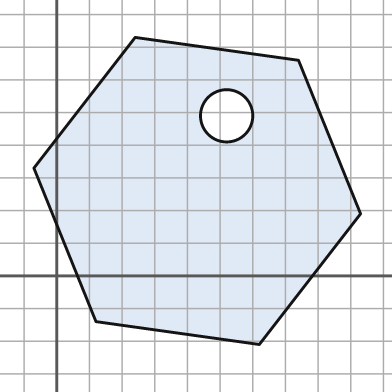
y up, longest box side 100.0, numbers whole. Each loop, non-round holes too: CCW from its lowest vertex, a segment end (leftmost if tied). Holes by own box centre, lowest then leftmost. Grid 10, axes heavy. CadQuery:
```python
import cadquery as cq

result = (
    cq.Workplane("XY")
    .moveTo(62.0, -21.0)
    .lineTo(93.0, 19.0)
    .lineTo(74.0, 66.0)
    .lineTo(24.0, 73.0)
    .lineTo(-7.0, 33.0)
    .lineTo(12.0, -14.0)
    .close()
    .moveTo(52.0, 49.0)
    .circle(8.0)
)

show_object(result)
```